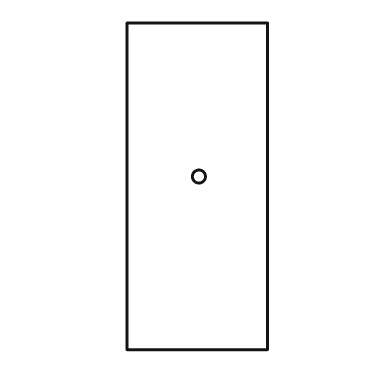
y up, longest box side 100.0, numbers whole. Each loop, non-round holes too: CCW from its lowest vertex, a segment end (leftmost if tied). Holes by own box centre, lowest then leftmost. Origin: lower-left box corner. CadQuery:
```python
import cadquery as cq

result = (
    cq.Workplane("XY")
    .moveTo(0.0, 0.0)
    .lineTo(43.0, 0.0)
    .lineTo(43.0, 100.0)
    .lineTo(0.0, 100.0)
    .close()
    .moveTo(22.0, 53.0)
    .circle(2.0)
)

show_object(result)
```